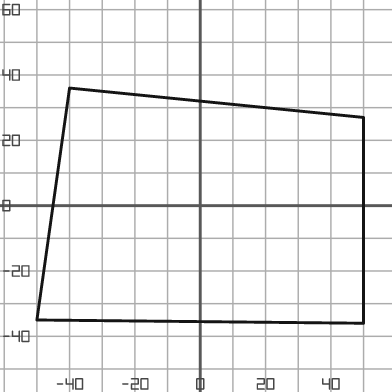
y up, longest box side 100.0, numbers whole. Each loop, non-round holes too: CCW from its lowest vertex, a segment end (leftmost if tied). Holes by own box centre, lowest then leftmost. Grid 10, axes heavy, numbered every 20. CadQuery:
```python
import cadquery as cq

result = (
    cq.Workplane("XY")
    .moveTo(50.0, -36.0)
    .lineTo(50.0, 27.0)
    .lineTo(-40.0, 36.0)
    .lineTo(-50.0, -35.0)
    .close()
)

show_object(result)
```